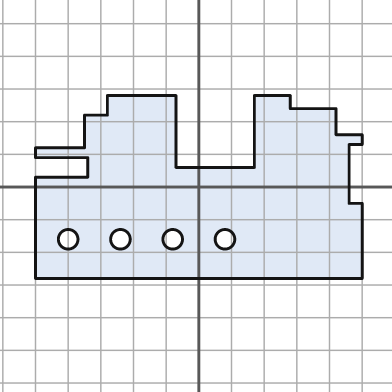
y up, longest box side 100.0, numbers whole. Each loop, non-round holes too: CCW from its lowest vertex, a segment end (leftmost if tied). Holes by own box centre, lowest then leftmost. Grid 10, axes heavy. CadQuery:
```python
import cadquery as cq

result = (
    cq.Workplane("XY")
    .moveTo(-50.0, -28.0)
    .lineTo(50.0, -28.0)
    .lineTo(50.0, -5.0)
    .lineTo(46.0, -5.0)
    .lineTo(46.0, 13.0)
    .lineTo(50.0, 13.0)
    .lineTo(50.0, 16.0)
    .lineTo(42.0, 16.0)
    .lineTo(42.0, 24.0)
    .lineTo(28.0, 24.0)
    .lineTo(28.0, 28.0)
    .lineTo(17.0, 28.0)
    .lineTo(17.0, 6.0)
    .lineTo(-7.0, 6.0)
    .lineTo(-7.0, 28.0)
    .lineTo(-28.0, 28.0)
    .lineTo(-28.0, 22.0)
    .lineTo(-35.0, 22.0)
    .lineTo(-35.0, 12.0)
    .lineTo(-50.0, 12.0)
    .lineTo(-50.0, 9.0)
    .lineTo(-34.0, 9.0)
    .lineTo(-34.0, 3.0)
    .lineTo(-50.0, 3.0)
    .close()
    .moveTo(-40.0, -16.0)
    .circle(3.0)
    .moveTo(-24.0, -16.0)
    .circle(3.0)
    .moveTo(-8.0, -16.0)
    .circle(3.0)
    .moveTo(8.0, -16.0)
    .circle(3.0)
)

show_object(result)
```